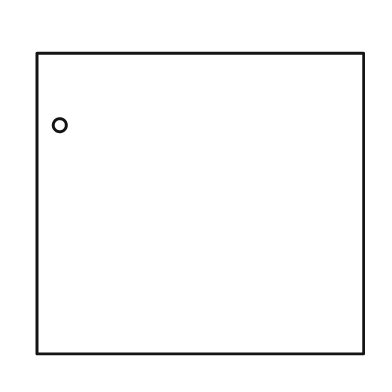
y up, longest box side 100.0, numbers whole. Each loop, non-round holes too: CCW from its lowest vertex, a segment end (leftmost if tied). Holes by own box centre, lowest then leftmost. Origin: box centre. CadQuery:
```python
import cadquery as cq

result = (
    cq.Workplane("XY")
    .moveTo(-50.0, -46.0)
    .lineTo(50.0, -46.0)
    .lineTo(50.0, 46.0)
    .lineTo(-50.0, 46.0)
    .close()
    .moveTo(-43.0, 24.0)
    .circle(2.0)
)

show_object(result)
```